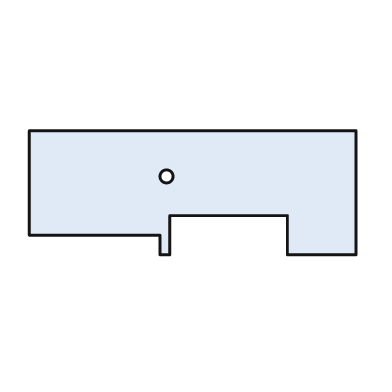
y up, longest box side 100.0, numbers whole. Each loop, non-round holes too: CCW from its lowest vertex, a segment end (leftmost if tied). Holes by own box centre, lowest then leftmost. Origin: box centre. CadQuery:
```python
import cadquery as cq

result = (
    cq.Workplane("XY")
    .moveTo(-10.0, -19.0)
    .lineTo(-7.0, -19.0)
    .lineTo(-7.0, -7.0)
    .lineTo(29.0, -7.0)
    .lineTo(29.0, -19.0)
    .lineTo(50.0, -19.0)
    .lineTo(50.0, 19.0)
    .lineTo(-50.0, 19.0)
    .lineTo(-50.0, -13.0)
    .lineTo(-10.0, -13.0)
    .close()
    .moveTo(-8.0, 5.0)
    .circle(2.0)
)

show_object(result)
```